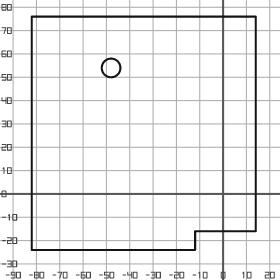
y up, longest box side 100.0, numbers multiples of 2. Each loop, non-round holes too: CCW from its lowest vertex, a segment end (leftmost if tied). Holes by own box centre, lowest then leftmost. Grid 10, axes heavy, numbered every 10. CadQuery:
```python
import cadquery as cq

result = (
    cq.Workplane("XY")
    .moveTo(-82.0, -24.0)
    .lineTo(-12.0, -24.0)
    .lineTo(-12.0, -16.0)
    .lineTo(14.0, -16.0)
    .lineTo(14.0, 76.0)
    .lineTo(-82.0, 76.0)
    .close()
    .moveTo(-48.0, 54.0)
    .circle(4.0)
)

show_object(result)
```